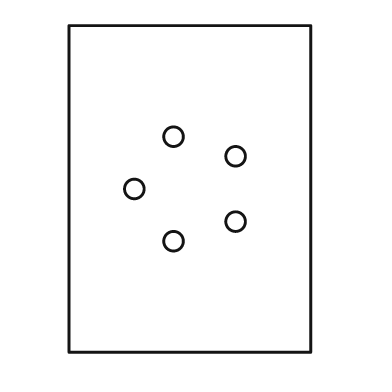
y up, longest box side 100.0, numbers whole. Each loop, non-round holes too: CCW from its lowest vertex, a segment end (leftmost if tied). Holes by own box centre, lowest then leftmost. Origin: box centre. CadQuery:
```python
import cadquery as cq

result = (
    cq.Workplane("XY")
    .moveTo(-37.0, -50.0)
    .lineTo(37.0, -50.0)
    .lineTo(37.0, 50.0)
    .lineTo(-37.0, 50.0)
    .close()
    .moveTo(-5.0, -16.0)
    .circle(3.0)
    .moveTo(14.0, -10.0)
    .circle(3.0)
    .moveTo(-17.0, 0.0)
    .circle(3.0)
    .moveTo(14.0, 10.0)
    .circle(3.0)
    .moveTo(-5.0, 16.0)
    .circle(3.0)
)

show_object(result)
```